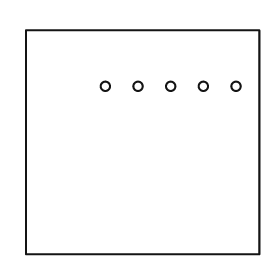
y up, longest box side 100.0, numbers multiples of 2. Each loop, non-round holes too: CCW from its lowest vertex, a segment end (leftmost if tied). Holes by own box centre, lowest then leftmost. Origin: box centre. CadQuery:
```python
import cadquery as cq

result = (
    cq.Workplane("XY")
    .moveTo(-50.0, -48.0)
    .lineTo(50.0, -48.0)
    .lineTo(50.0, 48.0)
    .lineTo(-50.0, 48.0)
    .close()
    .moveTo(-16.0, 24.0)
    .circle(2.0)
    .moveTo(-2.0, 24.0)
    .circle(2.0)
    .moveTo(12.0, 24.0)
    .circle(2.0)
    .moveTo(26.0, 24.0)
    .circle(2.0)
    .moveTo(40.0, 24.0)
    .circle(2.0)
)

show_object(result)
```